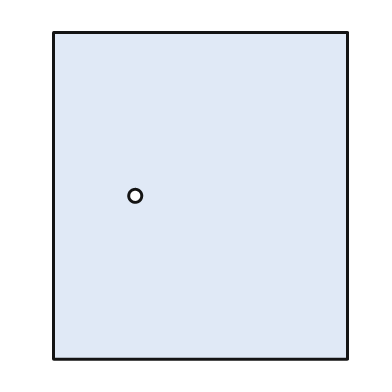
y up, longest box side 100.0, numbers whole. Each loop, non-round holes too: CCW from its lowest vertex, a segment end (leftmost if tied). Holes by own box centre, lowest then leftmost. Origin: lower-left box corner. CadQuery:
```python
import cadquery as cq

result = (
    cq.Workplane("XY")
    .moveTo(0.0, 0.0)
    .lineTo(90.0, 0.0)
    .lineTo(90.0, 100.0)
    .lineTo(0.0, 100.0)
    .close()
    .moveTo(25.0, 50.0)
    .circle(2.0)
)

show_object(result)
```